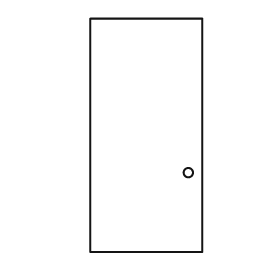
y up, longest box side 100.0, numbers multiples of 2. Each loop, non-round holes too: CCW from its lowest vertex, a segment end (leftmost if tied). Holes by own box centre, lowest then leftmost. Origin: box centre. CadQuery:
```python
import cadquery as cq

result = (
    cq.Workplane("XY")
    .moveTo(-24.0, -50.0)
    .lineTo(24.0, -50.0)
    .lineTo(24.0, 50.0)
    .lineTo(-24.0, 50.0)
    .close()
    .moveTo(18.0, -16.0)
    .circle(2.0)
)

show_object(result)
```